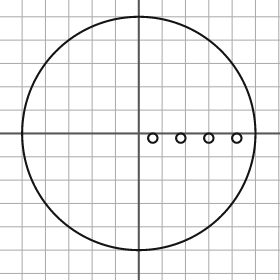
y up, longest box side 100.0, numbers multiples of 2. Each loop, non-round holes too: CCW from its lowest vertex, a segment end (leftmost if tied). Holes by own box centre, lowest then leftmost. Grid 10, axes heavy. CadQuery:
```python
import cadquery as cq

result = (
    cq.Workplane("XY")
    .moveTo(0.0, 0.0)
    .circle(50.0)
    .moveTo(6.0, -2.0)
    .circle(2.0)
    .moveTo(18.0, -2.0)
    .circle(2.0)
    .moveTo(30.0, -2.0)
    .circle(2.0)
    .moveTo(42.0, -2.0)
    .circle(2.0)
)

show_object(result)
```